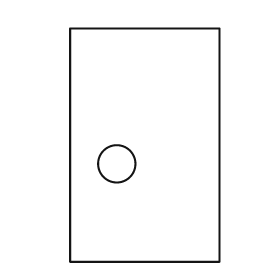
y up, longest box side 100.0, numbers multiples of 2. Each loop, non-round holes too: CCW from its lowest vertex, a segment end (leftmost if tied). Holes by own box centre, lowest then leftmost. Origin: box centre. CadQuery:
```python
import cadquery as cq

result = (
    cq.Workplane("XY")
    .moveTo(-32.0, -50.0)
    .lineTo(32.0, -50.0)
    .lineTo(32.0, 50.0)
    .lineTo(-32.0, 50.0)
    .close()
    .moveTo(-12.0, -8.0)
    .circle(8.0)
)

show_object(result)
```